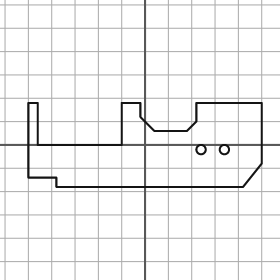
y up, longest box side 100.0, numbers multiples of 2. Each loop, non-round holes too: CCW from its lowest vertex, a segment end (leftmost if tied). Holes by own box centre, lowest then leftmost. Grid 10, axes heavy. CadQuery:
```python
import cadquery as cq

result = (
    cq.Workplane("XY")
    .moveTo(-38.0, -18.0)
    .lineTo(42.0, -18.0)
    .lineTo(50.0, -8.0)
    .lineTo(50.0, 18.0)
    .lineTo(22.0, 18.0)
    .lineTo(22.0, 10.0)
    .lineTo(18.0, 6.0)
    .lineTo(4.0, 6.0)
    .lineTo(-2.0, 12.0)
    .lineTo(-2.0, 18.0)
    .lineTo(-10.0, 18.0)
    .lineTo(-10.0, 0.0)
    .lineTo(-46.0, 0.0)
    .lineTo(-46.0, 18.0)
    .lineTo(-50.0, 18.0)
    .lineTo(-50.0, -14.0)
    .lineTo(-38.0, -14.0)
    .close()
    .moveTo(24.0, -2.0)
    .circle(2.0)
    .moveTo(34.0, -2.0)
    .circle(2.0)
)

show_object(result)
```